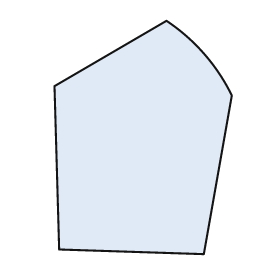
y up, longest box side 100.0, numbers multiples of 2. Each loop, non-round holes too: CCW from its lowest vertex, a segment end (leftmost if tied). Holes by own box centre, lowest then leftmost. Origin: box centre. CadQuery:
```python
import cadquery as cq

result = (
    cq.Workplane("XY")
    .moveTo(26.0, -50.0)
    .lineTo(38.0, 18.0)
    .threePointArc((26.0, 36.0), (10.0, 50.0))
    .lineTo(-38.0, 22.0)
    .lineTo(-36.0, -48.0)
    .close()
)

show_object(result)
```